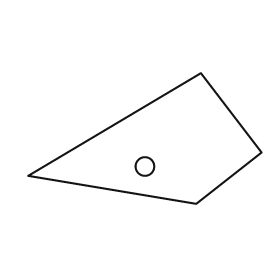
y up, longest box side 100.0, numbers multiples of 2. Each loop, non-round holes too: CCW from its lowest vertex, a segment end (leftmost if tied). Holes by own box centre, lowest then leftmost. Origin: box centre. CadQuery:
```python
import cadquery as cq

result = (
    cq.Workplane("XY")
    .moveTo(22.0, -28.0)
    .lineTo(50.0, -6.0)
    .lineTo(24.0, 28.0)
    .lineTo(-50.0, -16.0)
    .close()
    .moveTo(0.0, -12.0)
    .circle(4.0)
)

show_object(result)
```